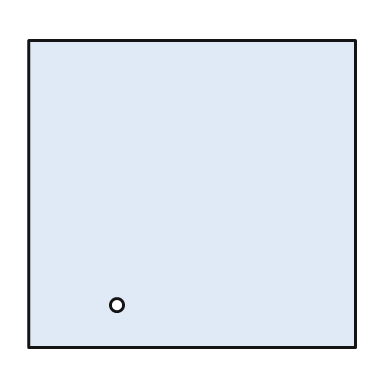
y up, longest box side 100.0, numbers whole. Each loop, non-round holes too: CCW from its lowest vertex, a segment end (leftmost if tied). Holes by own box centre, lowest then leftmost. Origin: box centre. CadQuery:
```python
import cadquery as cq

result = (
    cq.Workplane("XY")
    .moveTo(-50.0, -47.0)
    .lineTo(50.0, -47.0)
    .lineTo(50.0, 47.0)
    .lineTo(-50.0, 47.0)
    .close()
    .moveTo(-23.0, -34.0)
    .circle(2.0)
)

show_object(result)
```